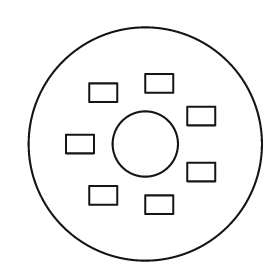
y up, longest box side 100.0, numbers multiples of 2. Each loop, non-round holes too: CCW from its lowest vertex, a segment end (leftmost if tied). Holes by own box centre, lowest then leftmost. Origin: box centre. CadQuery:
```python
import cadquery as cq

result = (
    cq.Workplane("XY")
    .moveTo(0.0, 0.0)
    .circle(50.0)
    .moveTo(0.0, -30.0)
    .lineTo(12.0, -30.0)
    .lineTo(12.0, -22.0)
    .lineTo(0.0, -22.0)
    .close()
    .moveTo(-24.0, -26.0)
    .lineTo(-12.0, -26.0)
    .lineTo(-12.0, -18.0)
    .lineTo(-24.0, -18.0)
    .close()
    .moveTo(18.0, -16.0)
    .lineTo(30.0, -16.0)
    .lineTo(30.0, -8.0)
    .lineTo(18.0, -8.0)
    .close()
    .moveTo(-34.0, -4.0)
    .lineTo(-22.0, -4.0)
    .lineTo(-22.0, 4.0)
    .lineTo(-34.0, 4.0)
    .close()
    .moveTo(0.0, 0.0)
    .circle(14.0)
    .moveTo(18.0, 8.0)
    .lineTo(30.0, 8.0)
    .lineTo(30.0, 16.0)
    .lineTo(18.0, 16.0)
    .close()
    .moveTo(-24.0, 18.0)
    .lineTo(-12.0, 18.0)
    .lineTo(-12.0, 26.0)
    .lineTo(-24.0, 26.0)
    .close()
    .moveTo(0.0, 22.0)
    .lineTo(12.0, 22.0)
    .lineTo(12.0, 30.0)
    .lineTo(0.0, 30.0)
    .close()
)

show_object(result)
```